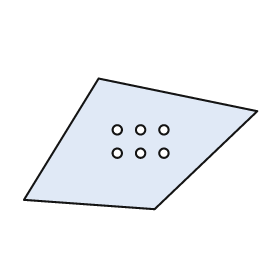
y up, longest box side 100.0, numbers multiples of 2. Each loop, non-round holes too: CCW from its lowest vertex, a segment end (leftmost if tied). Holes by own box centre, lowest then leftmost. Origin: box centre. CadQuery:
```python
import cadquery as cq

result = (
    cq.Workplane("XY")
    .moveTo(6.0, -28.0)
    .lineTo(50.0, 14.0)
    .lineTo(-18.0, 28.0)
    .lineTo(-50.0, -24.0)
    .close()
    .moveTo(-10.0, -4.0)
    .circle(2.0)
    .moveTo(0.0, -4.0)
    .circle(2.0)
    .moveTo(10.0, -4.0)
    .circle(2.0)
    .moveTo(-10.0, 6.0)
    .circle(2.0)
    .moveTo(0.0, 6.0)
    .circle(2.0)
    .moveTo(10.0, 6.0)
    .circle(2.0)
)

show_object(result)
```